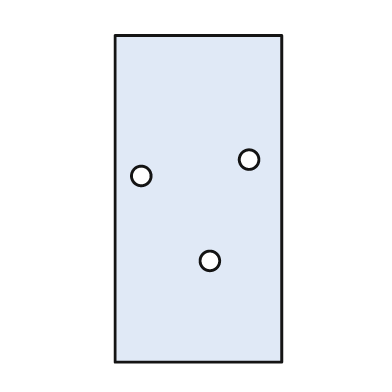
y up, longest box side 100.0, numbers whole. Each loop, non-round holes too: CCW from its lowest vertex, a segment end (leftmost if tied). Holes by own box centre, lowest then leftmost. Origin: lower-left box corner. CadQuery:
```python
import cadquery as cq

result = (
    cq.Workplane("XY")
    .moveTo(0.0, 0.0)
    .lineTo(51.0, 0.0)
    .lineTo(51.0, 100.0)
    .lineTo(0.0, 100.0)
    .close()
    .moveTo(29.0, 31.0)
    .circle(3.0)
    .moveTo(8.0, 57.0)
    .circle(3.0)
    .moveTo(41.0, 62.0)
    .circle(3.0)
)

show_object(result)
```